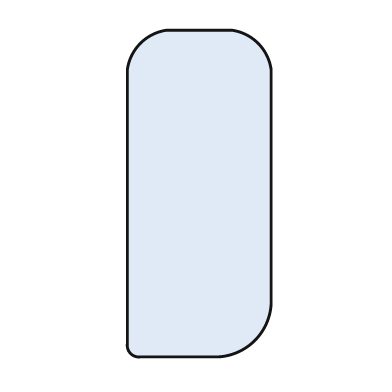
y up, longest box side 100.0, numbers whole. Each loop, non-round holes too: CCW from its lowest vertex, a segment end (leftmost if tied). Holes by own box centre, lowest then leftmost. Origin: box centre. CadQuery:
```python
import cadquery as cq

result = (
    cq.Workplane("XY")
    .moveTo(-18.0, -50.0)
    .lineTo(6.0, -50.0)
    .threePointArc((17.0, -45.0), (22.0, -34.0))
    .lineTo(22.0, 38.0)
    .threePointArc((18.0, 46.0), (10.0, 50.0))
    .lineTo(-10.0, 50.0)
    .threePointArc((-18.0, 46.0), (-22.0, 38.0))
    .lineTo(-22.0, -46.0)
    .threePointArc((-21.0, -49.0), (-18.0, -50.0))
    .close()
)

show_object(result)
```